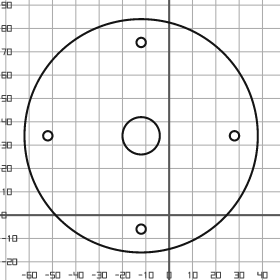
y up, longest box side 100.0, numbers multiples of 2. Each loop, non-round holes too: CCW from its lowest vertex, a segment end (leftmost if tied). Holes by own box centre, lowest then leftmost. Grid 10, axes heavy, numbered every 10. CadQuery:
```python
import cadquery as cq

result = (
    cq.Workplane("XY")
    .moveTo(-12.0, 34.0)
    .circle(50.0)
    .moveTo(-12.0, -6.0)
    .circle(2.0)
    .moveTo(-52.0, 34.0)
    .circle(2.0)
    .moveTo(-12.0, 34.0)
    .circle(8.0)
    .moveTo(28.0, 34.0)
    .circle(2.0)
    .moveTo(-12.0, 74.0)
    .circle(2.0)
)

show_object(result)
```